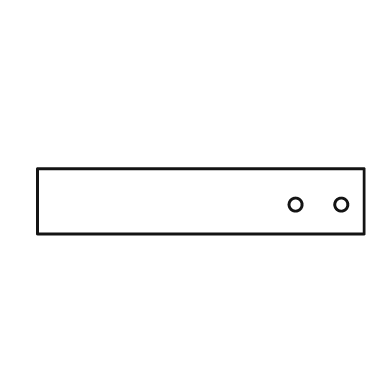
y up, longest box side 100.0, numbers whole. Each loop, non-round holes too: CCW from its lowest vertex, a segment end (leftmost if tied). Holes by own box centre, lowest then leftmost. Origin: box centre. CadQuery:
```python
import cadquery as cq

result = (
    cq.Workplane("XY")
    .moveTo(-50.0, -10.0)
    .lineTo(50.0, -10.0)
    .lineTo(50.0, 10.0)
    .lineTo(-50.0, 10.0)
    .close()
    .moveTo(29.0, -1.0)
    .circle(2.0)
    .moveTo(43.0, -1.0)
    .circle(2.0)
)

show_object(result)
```